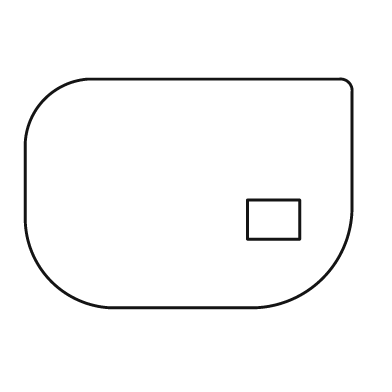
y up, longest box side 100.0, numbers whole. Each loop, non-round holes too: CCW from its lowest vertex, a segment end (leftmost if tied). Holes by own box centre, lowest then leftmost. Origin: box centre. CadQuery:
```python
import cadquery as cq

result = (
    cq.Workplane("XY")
    .moveTo(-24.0, -35.0)
    .lineTo(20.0, -35.0)
    .threePointArc((41.0, -26.0), (50.0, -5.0))
    .lineTo(50.0, 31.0)
    .threePointArc((49.0, 34.0), (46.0, 35.0))
    .lineTo(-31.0, 35.0)
    .threePointArc((-44.0, 29.0), (-50.0, 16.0))
    .lineTo(-50.0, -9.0)
    .threePointArc((-42.0, -27.0), (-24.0, -35.0))
    .close()
    .moveTo(18.0, -14.0)
    .lineTo(34.0, -14.0)
    .lineTo(34.0, -2.0)
    .lineTo(18.0, -2.0)
    .close()
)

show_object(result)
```